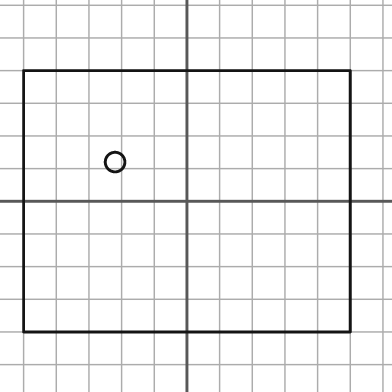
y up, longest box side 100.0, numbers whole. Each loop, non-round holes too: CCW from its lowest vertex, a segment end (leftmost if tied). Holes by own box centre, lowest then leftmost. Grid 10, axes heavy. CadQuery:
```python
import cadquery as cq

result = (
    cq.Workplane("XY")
    .moveTo(-50.0, -40.0)
    .lineTo(50.0, -40.0)
    .lineTo(50.0, 40.0)
    .lineTo(-50.0, 40.0)
    .close()
    .moveTo(-22.0, 12.0)
    .circle(3.0)
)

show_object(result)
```